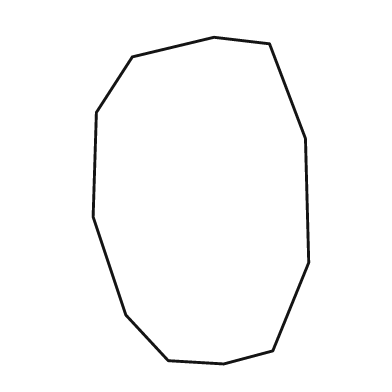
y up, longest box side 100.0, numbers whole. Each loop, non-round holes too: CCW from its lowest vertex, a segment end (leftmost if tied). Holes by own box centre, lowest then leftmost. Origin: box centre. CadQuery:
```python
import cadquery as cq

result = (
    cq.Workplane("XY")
    .moveTo(7.0, -50.0)
    .lineTo(22.0, -46.0)
    .lineTo(33.0, -19.0)
    .lineTo(32.0, 19.0)
    .lineTo(21.0, 48.0)
    .lineTo(4.0, 50.0)
    .lineTo(-21.0, 44.0)
    .lineTo(-32.0, 27.0)
    .lineTo(-33.0, -5.0)
    .lineTo(-23.0, -35.0)
    .lineTo(-10.0, -49.0)
    .close()
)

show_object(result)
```